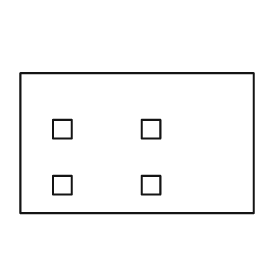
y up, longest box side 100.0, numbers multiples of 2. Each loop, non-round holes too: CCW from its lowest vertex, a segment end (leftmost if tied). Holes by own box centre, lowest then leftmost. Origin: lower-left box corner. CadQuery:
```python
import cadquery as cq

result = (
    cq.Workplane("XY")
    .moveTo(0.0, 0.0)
    .lineTo(100.0, 0.0)
    .lineTo(100.0, 60.0)
    .lineTo(0.0, 60.0)
    .close()
    .moveTo(14.0, 8.0)
    .lineTo(22.0, 8.0)
    .lineTo(22.0, 16.0)
    .lineTo(14.0, 16.0)
    .close()
    .moveTo(52.0, 8.0)
    .lineTo(60.0, 8.0)
    .lineTo(60.0, 16.0)
    .lineTo(52.0, 16.0)
    .close()
    .moveTo(14.0, 32.0)
    .lineTo(22.0, 32.0)
    .lineTo(22.0, 40.0)
    .lineTo(14.0, 40.0)
    .close()
    .moveTo(52.0, 32.0)
    .lineTo(60.0, 32.0)
    .lineTo(60.0, 40.0)
    .lineTo(52.0, 40.0)
    .close()
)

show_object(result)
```